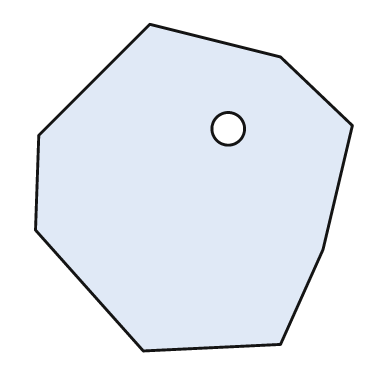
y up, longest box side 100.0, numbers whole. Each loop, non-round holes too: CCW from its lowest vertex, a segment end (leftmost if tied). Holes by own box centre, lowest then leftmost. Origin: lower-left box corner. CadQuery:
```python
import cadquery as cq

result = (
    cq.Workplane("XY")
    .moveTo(33.0, 0.0)
    .lineTo(75.0, 2.0)
    .lineTo(88.0, 31.0)
    .lineTo(97.0, 69.0)
    .lineTo(75.0, 90.0)
    .lineTo(35.0, 100.0)
    .lineTo(1.0, 66.0)
    .lineTo(0.0, 37.0)
    .close()
    .moveTo(59.0, 68.0)
    .circle(5.0)
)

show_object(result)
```